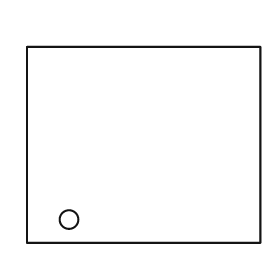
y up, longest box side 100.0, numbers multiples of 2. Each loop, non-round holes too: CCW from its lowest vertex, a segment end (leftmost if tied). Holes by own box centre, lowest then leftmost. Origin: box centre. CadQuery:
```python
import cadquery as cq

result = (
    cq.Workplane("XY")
    .moveTo(-50.0, -42.0)
    .lineTo(50.0, -42.0)
    .lineTo(50.0, 42.0)
    .lineTo(-50.0, 42.0)
    .close()
    .moveTo(-32.0, -32.0)
    .circle(4.0)
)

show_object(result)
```